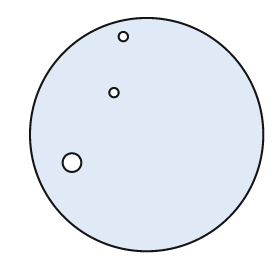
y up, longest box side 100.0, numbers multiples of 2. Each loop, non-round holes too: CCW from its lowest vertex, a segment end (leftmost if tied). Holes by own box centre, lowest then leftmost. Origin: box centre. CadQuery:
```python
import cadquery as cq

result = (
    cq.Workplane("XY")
    .moveTo(0.0, 0.0)
    .circle(50.0)
    .moveTo(-32.0, -12.0)
    .circle(4.0)
    .moveTo(-14.0, 18.0)
    .circle(2.0)
    .moveTo(-10.0, 42.0)
    .circle(2.0)
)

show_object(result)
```